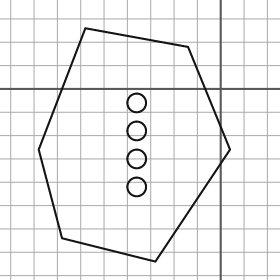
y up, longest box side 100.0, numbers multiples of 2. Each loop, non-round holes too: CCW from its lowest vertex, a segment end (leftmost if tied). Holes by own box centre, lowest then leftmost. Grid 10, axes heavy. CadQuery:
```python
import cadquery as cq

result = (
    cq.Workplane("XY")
    .moveTo(-28.0, -74.0)
    .lineTo(4.0, -26.0)
    .lineTo(-14.0, 18.0)
    .lineTo(-58.0, 26.0)
    .lineTo(-78.0, -26.0)
    .lineTo(-68.0, -64.0)
    .close()
    .moveTo(-36.0, -42.0)
    .circle(4.0)
    .moveTo(-36.0, -30.0)
    .circle(4.0)
    .moveTo(-36.0, -18.0)
    .circle(4.0)
    .moveTo(-36.0, -6.0)
    .circle(4.0)
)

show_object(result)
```